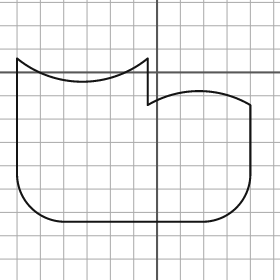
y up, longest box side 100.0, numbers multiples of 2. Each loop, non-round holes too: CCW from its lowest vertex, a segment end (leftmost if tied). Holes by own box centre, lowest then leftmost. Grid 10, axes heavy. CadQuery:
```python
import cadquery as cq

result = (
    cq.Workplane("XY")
    .moveTo(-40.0, -64.0)
    .lineTo(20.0, -64.0)
    .threePointArc((34.0, -58.0), (40.0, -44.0))
    .lineTo(40.0, -14.0)
    .threePointArc((18.0, -8.0), (-4.0, -14.0))
    .lineTo(-4.0, 6.0)
    .threePointArc((-32.0, -4.0), (-60.0, 6.0))
    .lineTo(-60.0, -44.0)
    .threePointArc((-54.0, -58.0), (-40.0, -64.0))
    .close()
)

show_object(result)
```